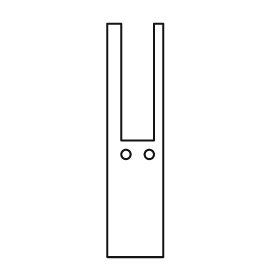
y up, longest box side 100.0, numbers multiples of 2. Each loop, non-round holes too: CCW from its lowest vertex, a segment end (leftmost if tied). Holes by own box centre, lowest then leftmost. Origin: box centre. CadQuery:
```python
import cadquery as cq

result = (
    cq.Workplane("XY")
    .moveTo(-12.0, -50.0)
    .lineTo(12.0, -50.0)
    .lineTo(12.0, 50.0)
    .lineTo(8.0, 50.0)
    .lineTo(8.0, 0.0)
    .lineTo(-6.0, 0.0)
    .lineTo(-6.0, 50.0)
    .lineTo(-12.0, 50.0)
    .close()
    .moveTo(-4.0, -6.0)
    .circle(2.0)
    .moveTo(6.0, -6.0)
    .circle(2.0)
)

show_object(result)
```